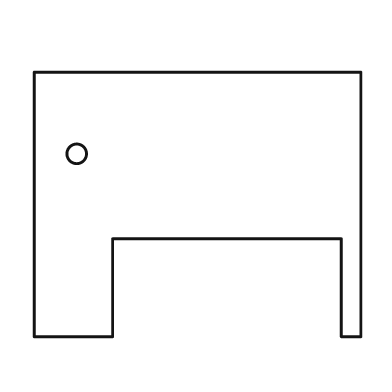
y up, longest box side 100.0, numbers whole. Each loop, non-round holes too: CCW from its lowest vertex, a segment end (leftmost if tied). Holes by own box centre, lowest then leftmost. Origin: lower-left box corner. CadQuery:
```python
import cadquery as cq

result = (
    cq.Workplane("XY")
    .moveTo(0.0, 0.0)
    .lineTo(24.0, 0.0)
    .lineTo(24.0, 30.0)
    .lineTo(94.0, 30.0)
    .lineTo(94.0, 0.0)
    .lineTo(100.0, 0.0)
    .lineTo(100.0, 81.0)
    .lineTo(0.0, 81.0)
    .close()
    .moveTo(13.0, 56.0)
    .circle(3.0)
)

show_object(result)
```